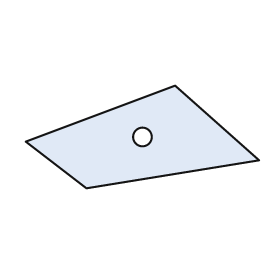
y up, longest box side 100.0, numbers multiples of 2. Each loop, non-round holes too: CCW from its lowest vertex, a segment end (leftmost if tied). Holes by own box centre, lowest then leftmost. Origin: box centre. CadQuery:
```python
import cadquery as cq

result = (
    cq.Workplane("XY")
    .moveTo(-24.0, -22.0)
    .lineTo(50.0, -10.0)
    .lineTo(14.0, 22.0)
    .lineTo(-50.0, -2.0)
    .close()
    .moveTo(0.0, 0.0)
    .circle(4.0)
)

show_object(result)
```